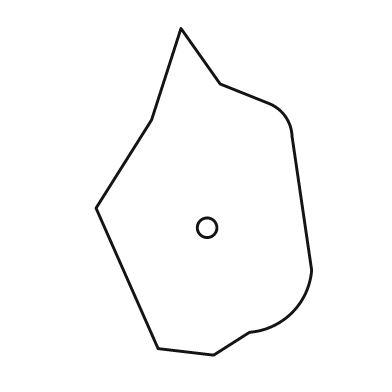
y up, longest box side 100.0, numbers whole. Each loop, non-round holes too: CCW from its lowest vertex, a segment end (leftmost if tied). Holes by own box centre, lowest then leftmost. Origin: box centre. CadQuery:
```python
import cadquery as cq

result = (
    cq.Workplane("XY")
    .moveTo(3.0, -50.0)
    .lineTo(14.0, -43.0)
    .threePointArc((27.0, -37.0), (33.0, -24.0))
    .lineTo(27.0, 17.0)
    .threePointArc((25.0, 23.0), (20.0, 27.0))
    .lineTo(5.0, 33.0)
    .lineTo(-7.0, 50.0)
    .lineTo(-16.0, 22.0)
    .lineTo(-33.0, -5.0)
    .lineTo(-14.0, -48.0)
    .close()
    .moveTo(1.0, -11.0)
    .circle(3.0)
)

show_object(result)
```